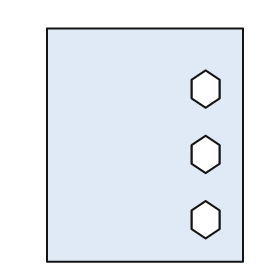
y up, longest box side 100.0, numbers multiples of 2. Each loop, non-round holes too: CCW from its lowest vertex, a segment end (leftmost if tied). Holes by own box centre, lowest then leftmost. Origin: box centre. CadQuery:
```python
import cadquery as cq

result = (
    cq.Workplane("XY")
    .moveTo(-42.0, -50.0)
    .lineTo(42.0, -50.0)
    .lineTo(42.0, 50.0)
    .lineTo(-42.0, 50.0)
    .close()
    .moveTo(26.0, -40.0)
    .lineTo(32.0, -36.0)
    .lineTo(32.0, -28.0)
    .lineTo(26.0, -24.0)
    .lineTo(20.0, -28.0)
    .lineTo(20.0, -36.0)
    .close()
    .moveTo(26.0, -12.0)
    .lineTo(32.0, -8.0)
    .lineTo(32.0, 0.0)
    .lineTo(26.0, 4.0)
    .lineTo(20.0, 0.0)
    .lineTo(20.0, -8.0)
    .close()
    .moveTo(26.0, 16.0)
    .lineTo(32.0, 20.0)
    .lineTo(32.0, 28.0)
    .lineTo(26.0, 32.0)
    .lineTo(20.0, 28.0)
    .lineTo(20.0, 20.0)
    .close()
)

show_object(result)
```